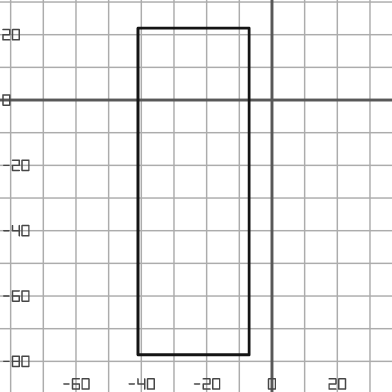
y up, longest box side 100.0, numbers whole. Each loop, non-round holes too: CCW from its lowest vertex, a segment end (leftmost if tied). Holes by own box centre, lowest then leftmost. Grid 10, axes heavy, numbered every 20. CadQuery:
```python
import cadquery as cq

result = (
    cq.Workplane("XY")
    .moveTo(-41.0, -78.0)
    .lineTo(-7.0, -78.0)
    .lineTo(-7.0, 22.0)
    .lineTo(-41.0, 22.0)
    .close()
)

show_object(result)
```